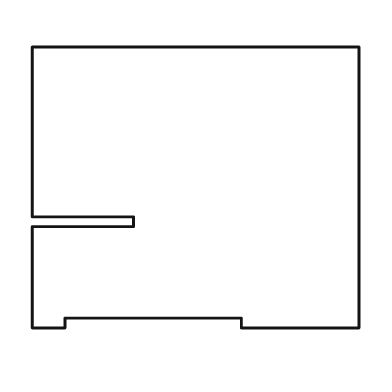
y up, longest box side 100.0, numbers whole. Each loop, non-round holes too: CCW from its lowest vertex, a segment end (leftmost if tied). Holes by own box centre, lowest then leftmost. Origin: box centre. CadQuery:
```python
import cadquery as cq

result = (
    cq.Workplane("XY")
    .moveTo(-50.0, -43.0)
    .lineTo(-40.0, -43.0)
    .lineTo(-40.0, -40.0)
    .lineTo(14.0, -40.0)
    .lineTo(14.0, -43.0)
    .lineTo(50.0, -43.0)
    .lineTo(50.0, 43.0)
    .lineTo(-50.0, 43.0)
    .lineTo(-50.0, -9.0)
    .lineTo(-19.0, -9.0)
    .lineTo(-19.0, -12.0)
    .lineTo(-50.0, -12.0)
    .close()
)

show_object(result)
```